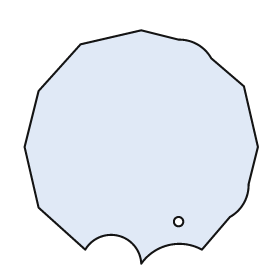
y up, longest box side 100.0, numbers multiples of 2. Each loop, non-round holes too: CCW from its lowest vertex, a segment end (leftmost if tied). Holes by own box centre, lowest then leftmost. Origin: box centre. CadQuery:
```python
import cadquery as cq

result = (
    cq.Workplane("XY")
    .moveTo(0.0, -50.0)
    .threePointArc((12.0, -42.0), (26.0, -44.0))
    .lineTo(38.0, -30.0)
    .threePointArc((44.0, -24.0), (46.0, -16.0))
    .lineTo(50.0, 0.0)
    .lineTo(44.0, 26.0)
    .lineTo(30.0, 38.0)
    .threePointArc((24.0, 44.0), (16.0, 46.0))
    .lineTo(0.0, 50.0)
    .lineTo(-26.0, 44.0)
    .lineTo(-44.0, 24.0)
    .lineTo(-50.0, 0.0)
    .lineTo(-44.0, -26.0)
    .lineTo(-24.0, -44.0)
    .threePointArc((-10.0, -38.0), (0.0, -50.0))
    .close()
    .moveTo(16.0, -32.0)
    .circle(2.0)
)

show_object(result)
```